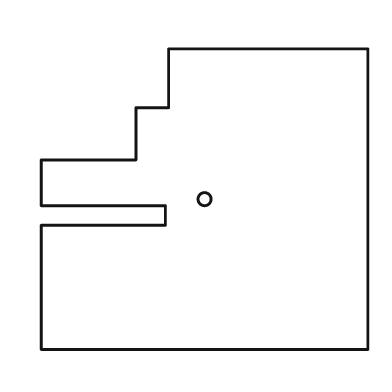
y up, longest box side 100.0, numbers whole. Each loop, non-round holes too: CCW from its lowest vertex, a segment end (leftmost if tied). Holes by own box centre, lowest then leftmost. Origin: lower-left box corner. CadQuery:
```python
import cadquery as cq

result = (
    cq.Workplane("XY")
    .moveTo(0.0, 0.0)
    .lineTo(100.0, 0.0)
    .lineTo(100.0, 92.0)
    .lineTo(39.0, 92.0)
    .lineTo(39.0, 74.0)
    .lineTo(29.0, 74.0)
    .lineTo(29.0, 58.0)
    .lineTo(0.0, 58.0)
    .lineTo(0.0, 44.0)
    .lineTo(38.0, 44.0)
    .lineTo(38.0, 38.0)
    .lineTo(0.0, 38.0)
    .close()
    .moveTo(50.0, 46.0)
    .circle(2.0)
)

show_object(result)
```